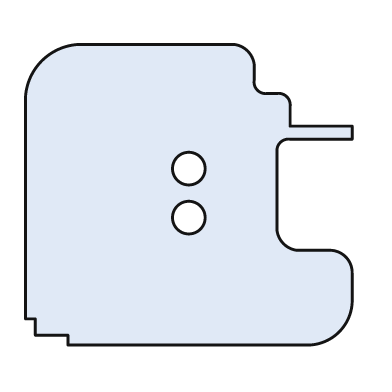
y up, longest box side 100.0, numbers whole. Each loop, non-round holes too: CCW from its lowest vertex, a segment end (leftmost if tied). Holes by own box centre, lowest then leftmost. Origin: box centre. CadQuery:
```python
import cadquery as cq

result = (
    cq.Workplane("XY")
    .moveTo(-37.0, -46.0)
    .lineTo(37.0, -46.0)
    .threePointArc((46.0, -42.0), (50.0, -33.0))
    .lineTo(50.0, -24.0)
    .threePointArc((48.0, -19.0), (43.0, -17.0))
    .lineTo(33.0, -17.0)
    .threePointArc((29.0, -15.0), (27.0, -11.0))
    .lineTo(27.0, 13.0)
    .threePointArc((28.0, 16.0), (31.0, 17.0))
    .lineTo(50.0, 17.0)
    .lineTo(50.0, 21.0)
    .lineTo(31.0, 21.0)
    .lineTo(31.0, 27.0)
    .threePointArc((30.0, 30.0), (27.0, 31.0))
    .lineTo(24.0, 31.0)
    .threePointArc((21.0, 32.0), (20.0, 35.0))
    .lineTo(20.0, 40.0)
    .threePointArc((18.0, 44.0), (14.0, 46.0))
    .lineTo(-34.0, 46.0)
    .threePointArc((-45.0, 41.0), (-50.0, 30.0))
    .lineTo(-50.0, -38.0)
    .lineTo(-47.0, -38.0)
    .lineTo(-47.0, -43.0)
    .lineTo(-37.0, -43.0)
    .close()
    .moveTo(0.0, -7.0)
    .circle(5.0)
    .moveTo(0.0, 8.0)
    .circle(5.0)
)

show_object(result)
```